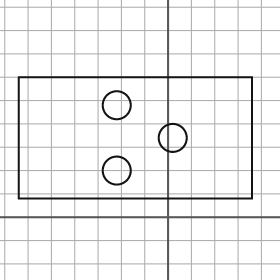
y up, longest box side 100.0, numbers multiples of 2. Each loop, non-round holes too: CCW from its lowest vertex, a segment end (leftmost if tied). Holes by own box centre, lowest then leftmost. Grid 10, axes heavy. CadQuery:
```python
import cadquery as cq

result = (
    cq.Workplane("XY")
    .moveTo(-64.0, 8.0)
    .lineTo(36.0, 8.0)
    .lineTo(36.0, 60.0)
    .lineTo(-64.0, 60.0)
    .close()
    .moveTo(-22.0, 20.0)
    .circle(6.0)
    .moveTo(2.0, 34.0)
    .circle(6.0)
    .moveTo(-22.0, 48.0)
    .circle(6.0)
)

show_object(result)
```